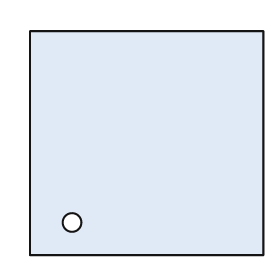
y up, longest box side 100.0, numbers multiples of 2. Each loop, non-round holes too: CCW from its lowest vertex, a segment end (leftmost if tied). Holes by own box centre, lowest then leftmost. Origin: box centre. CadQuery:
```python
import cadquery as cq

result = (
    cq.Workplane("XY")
    .moveTo(-50.0, -48.0)
    .lineTo(50.0, -48.0)
    .lineTo(50.0, 48.0)
    .lineTo(-50.0, 48.0)
    .close()
    .moveTo(-32.0, -34.0)
    .circle(4.0)
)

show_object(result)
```